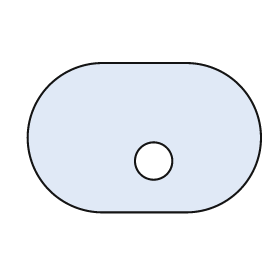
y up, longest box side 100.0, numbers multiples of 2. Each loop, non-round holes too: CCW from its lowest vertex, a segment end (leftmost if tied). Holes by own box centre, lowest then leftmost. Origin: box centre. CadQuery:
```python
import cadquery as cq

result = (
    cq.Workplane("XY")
    .moveTo(-18.0, -32.0)
    .lineTo(18.0, -32.0)
    .threePointArc((50.0, 0.0), (18.0, 32.0))
    .lineTo(-18.0, 32.0)
    .threePointArc((-50.0, 0.0), (-18.0, -32.0))
    .close()
    .moveTo(4.0, -10.0)
    .circle(8.0)
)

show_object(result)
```